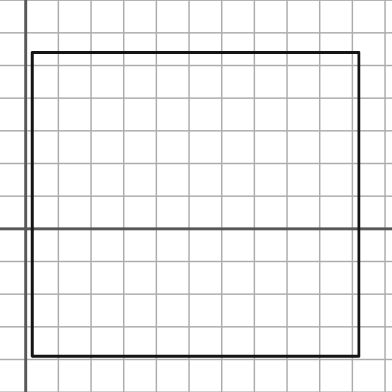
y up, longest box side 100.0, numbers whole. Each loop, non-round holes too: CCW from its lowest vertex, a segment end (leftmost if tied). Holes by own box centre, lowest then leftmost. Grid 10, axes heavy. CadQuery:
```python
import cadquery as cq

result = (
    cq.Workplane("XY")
    .moveTo(2.0, -39.0)
    .lineTo(102.0, -39.0)
    .lineTo(102.0, 54.0)
    .lineTo(2.0, 54.0)
    .close()
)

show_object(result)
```